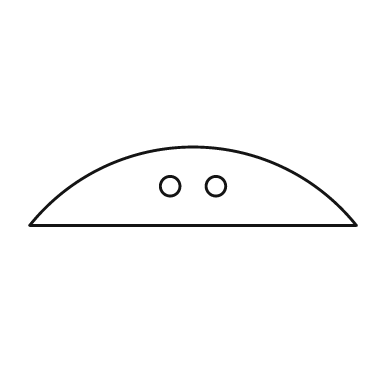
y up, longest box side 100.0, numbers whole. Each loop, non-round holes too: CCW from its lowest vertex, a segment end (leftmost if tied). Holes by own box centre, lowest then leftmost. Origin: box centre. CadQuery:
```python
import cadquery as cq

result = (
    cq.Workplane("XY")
    .moveTo(-50.0, -12.0)
    .lineTo(50.0, -12.0)
    .threePointArc((0.0, 12.0), (-50.0, -12.0))
    .close()
    .moveTo(-7.0, 0.0)
    .circle(3.0)
    .moveTo(7.0, 0.0)
    .circle(3.0)
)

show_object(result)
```